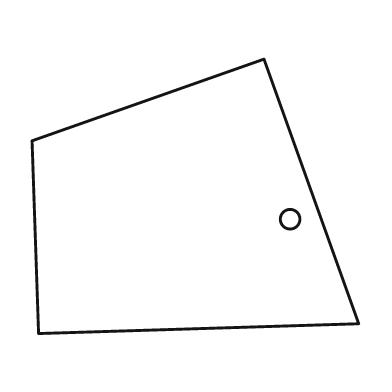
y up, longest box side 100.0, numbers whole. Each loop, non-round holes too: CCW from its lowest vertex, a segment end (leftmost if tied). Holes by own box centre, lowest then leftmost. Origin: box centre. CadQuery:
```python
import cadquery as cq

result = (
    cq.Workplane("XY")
    .moveTo(-48.0, -42.0)
    .lineTo(50.0, -39.0)
    .lineTo(21.0, 42.0)
    .lineTo(-50.0, 17.0)
    .close()
    .moveTo(29.0, -7.0)
    .circle(3.0)
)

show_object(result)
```